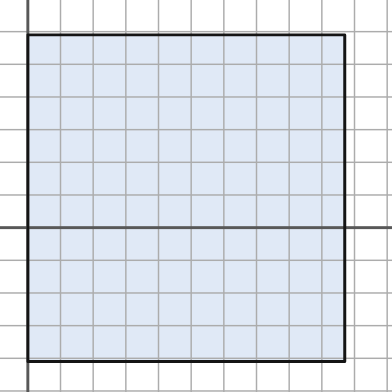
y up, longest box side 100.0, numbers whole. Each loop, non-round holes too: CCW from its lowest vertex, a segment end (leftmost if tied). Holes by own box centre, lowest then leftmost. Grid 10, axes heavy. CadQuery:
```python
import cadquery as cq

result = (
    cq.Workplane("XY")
    .moveTo(0.0, -41.0)
    .lineTo(97.0, -41.0)
    .lineTo(97.0, 59.0)
    .lineTo(0.0, 59.0)
    .close()
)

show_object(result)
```